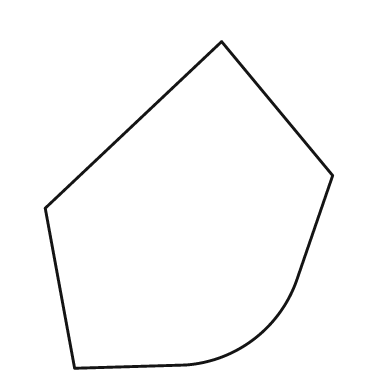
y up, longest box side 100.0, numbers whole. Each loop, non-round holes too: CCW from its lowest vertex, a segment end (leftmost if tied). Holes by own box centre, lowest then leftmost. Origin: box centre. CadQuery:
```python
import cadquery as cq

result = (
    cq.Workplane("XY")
    .moveTo(-35.0, -50.0)
    .lineTo(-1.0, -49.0)
    .threePointArc((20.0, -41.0), (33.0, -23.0))
    .lineTo(44.0, 9.0)
    .lineTo(10.0, 50.0)
    .lineTo(-44.0, -1.0)
    .close()
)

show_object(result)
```